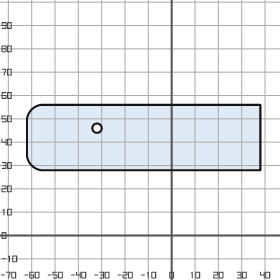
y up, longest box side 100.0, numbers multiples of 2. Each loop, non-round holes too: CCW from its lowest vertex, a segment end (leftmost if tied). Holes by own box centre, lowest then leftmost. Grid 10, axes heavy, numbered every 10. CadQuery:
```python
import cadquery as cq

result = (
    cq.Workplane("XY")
    .moveTo(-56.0, 28.0)
    .lineTo(38.0, 28.0)
    .lineTo(38.0, 56.0)
    .lineTo(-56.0, 56.0)
    .threePointArc((-60.0, 54.0), (-62.0, 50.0))
    .lineTo(-62.0, 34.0)
    .threePointArc((-60.0, 30.0), (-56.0, 28.0))
    .close()
    .moveTo(-32.0, 46.0)
    .circle(2.0)
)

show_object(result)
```